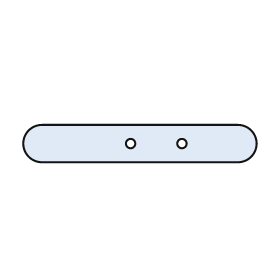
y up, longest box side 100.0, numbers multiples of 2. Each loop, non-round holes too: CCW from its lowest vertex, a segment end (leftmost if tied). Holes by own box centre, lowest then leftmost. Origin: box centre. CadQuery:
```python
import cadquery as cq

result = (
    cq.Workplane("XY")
    .moveTo(-42.0, -8.0)
    .lineTo(42.0, -8.0)
    .threePointArc((50.0, 0.0), (42.0, 8.0))
    .lineTo(-42.0, 8.0)
    .threePointArc((-50.0, 0.0), (-42.0, -8.0))
    .close()
    .moveTo(-4.0, 0.0)
    .circle(2.0)
    .moveTo(18.0, 0.0)
    .circle(2.0)
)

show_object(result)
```